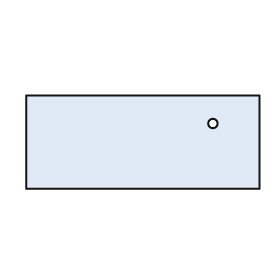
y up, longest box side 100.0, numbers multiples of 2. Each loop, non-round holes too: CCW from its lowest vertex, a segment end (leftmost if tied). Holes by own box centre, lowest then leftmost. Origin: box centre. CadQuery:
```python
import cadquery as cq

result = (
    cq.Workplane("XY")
    .moveTo(-50.0, -20.0)
    .lineTo(50.0, -20.0)
    .lineTo(50.0, 20.0)
    .lineTo(-50.0, 20.0)
    .close()
    .moveTo(30.0, 8.0)
    .circle(2.0)
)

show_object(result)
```